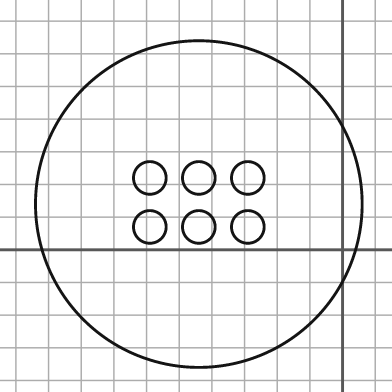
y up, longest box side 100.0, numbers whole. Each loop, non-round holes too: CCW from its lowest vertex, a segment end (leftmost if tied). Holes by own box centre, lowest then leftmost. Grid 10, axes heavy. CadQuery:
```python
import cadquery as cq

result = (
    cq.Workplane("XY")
    .moveTo(-44.0, 14.0)
    .circle(50.0)
    .moveTo(-59.0, 7.0)
    .circle(5.0)
    .moveTo(-44.0, 7.0)
    .circle(5.0)
    .moveTo(-29.0, 7.0)
    .circle(5.0)
    .moveTo(-59.0, 22.0)
    .circle(5.0)
    .moveTo(-44.0, 22.0)
    .circle(5.0)
    .moveTo(-29.0, 22.0)
    .circle(5.0)
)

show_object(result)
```